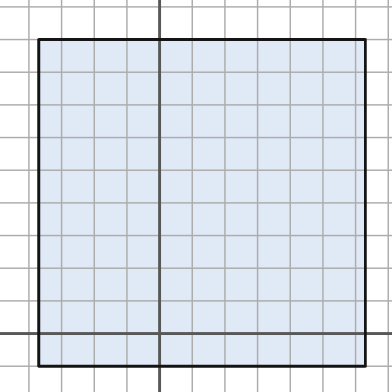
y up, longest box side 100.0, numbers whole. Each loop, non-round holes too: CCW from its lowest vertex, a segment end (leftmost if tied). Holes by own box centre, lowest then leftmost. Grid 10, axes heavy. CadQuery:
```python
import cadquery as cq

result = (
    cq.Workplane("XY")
    .moveTo(-37.0, -10.0)
    .lineTo(63.0, -10.0)
    .lineTo(63.0, 90.0)
    .lineTo(-37.0, 90.0)
    .close()
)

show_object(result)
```